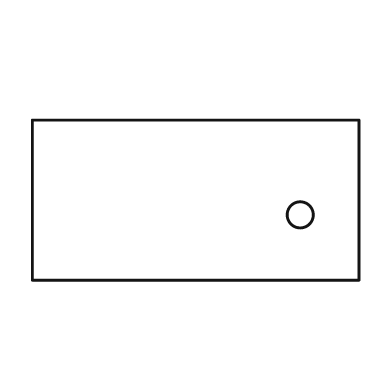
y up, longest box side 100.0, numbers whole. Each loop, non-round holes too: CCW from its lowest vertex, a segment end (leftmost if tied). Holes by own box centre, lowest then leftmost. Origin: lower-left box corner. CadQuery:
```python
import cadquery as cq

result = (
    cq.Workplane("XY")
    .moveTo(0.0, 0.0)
    .lineTo(100.0, 0.0)
    .lineTo(100.0, 49.0)
    .lineTo(0.0, 49.0)
    .close()
    .moveTo(82.0, 20.0)
    .circle(4.0)
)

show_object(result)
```